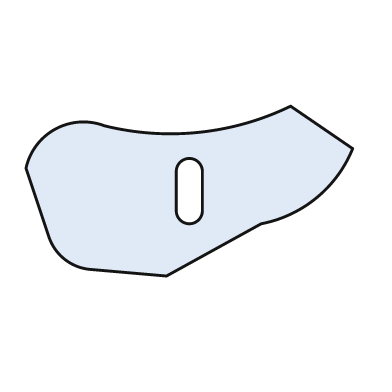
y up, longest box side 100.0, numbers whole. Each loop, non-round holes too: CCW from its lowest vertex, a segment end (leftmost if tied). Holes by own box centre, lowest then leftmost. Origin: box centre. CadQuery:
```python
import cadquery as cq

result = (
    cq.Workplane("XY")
    .moveTo(-7.0, -26.0)
    .lineTo(22.0, -10.0)
    .threePointArc((39.0, -2.0), (50.0, 13.0))
    .lineTo(31.0, 26.0)
    .threePointArc((3.0, 18.0), (-26.0, 20.0))
    .threePointArc((-41.0, 19.0), (-50.0, 7.0))
    .lineTo(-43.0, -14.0)
    .threePointArc((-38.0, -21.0), (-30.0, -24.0))
    .close()
    .moveTo(-4.0, -6.0)
    .threePointArc((0.0, -10.0), (4.0, -6.0))
    .lineTo(4.0, 6.0)
    .threePointArc((0.0, 10.0), (-4.0, 6.0))
    .close()
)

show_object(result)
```